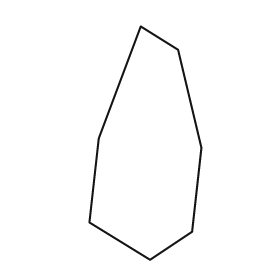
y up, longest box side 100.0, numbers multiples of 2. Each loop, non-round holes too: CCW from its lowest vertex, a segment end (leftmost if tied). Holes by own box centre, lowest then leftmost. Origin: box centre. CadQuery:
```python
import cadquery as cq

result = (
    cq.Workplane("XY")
    .moveTo(2.0, -50.0)
    .lineTo(20.0, -38.0)
    .lineTo(24.0, -2.0)
    .lineTo(14.0, 40.0)
    .lineTo(-2.0, 50.0)
    .lineTo(-20.0, 2.0)
    .lineTo(-24.0, -34.0)
    .close()
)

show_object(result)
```